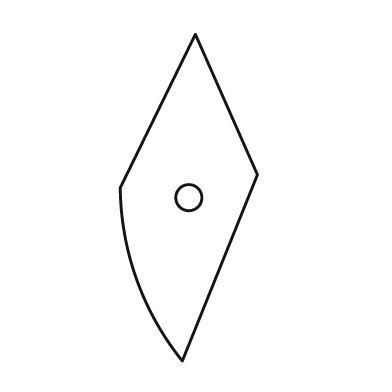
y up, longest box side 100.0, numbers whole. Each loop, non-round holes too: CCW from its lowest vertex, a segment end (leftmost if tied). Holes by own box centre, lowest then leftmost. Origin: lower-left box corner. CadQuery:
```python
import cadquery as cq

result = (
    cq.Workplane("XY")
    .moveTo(19.0, 0.0)
    .lineTo(42.0, 57.0)
    .lineTo(23.0, 100.0)
    .lineTo(0.0, 53.0)
    .threePointArc((5.0, 25.0), (19.0, 0.0))
    .close()
    .moveTo(21.0, 50.0)
    .circle(4.0)
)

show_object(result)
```